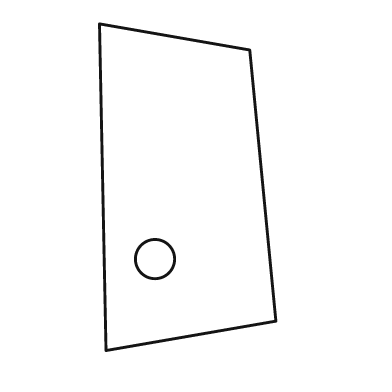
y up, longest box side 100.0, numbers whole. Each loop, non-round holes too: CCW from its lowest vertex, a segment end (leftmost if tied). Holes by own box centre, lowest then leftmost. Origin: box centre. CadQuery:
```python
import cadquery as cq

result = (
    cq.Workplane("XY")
    .moveTo(-25.0, -50.0)
    .lineTo(27.0, -41.0)
    .lineTo(19.0, 42.0)
    .lineTo(-27.0, 50.0)
    .close()
    .moveTo(-10.0, -22.0)
    .circle(6.0)
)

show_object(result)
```